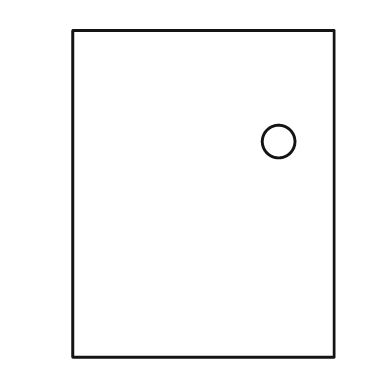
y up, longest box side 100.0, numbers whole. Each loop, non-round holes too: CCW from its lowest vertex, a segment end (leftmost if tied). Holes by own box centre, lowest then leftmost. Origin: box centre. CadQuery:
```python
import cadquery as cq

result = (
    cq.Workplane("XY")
    .moveTo(-40.0, -50.0)
    .lineTo(40.0, -50.0)
    .lineTo(40.0, 50.0)
    .lineTo(-40.0, 50.0)
    .close()
    .moveTo(23.0, 16.0)
    .circle(5.0)
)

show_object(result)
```